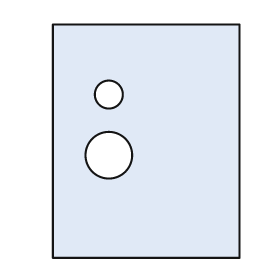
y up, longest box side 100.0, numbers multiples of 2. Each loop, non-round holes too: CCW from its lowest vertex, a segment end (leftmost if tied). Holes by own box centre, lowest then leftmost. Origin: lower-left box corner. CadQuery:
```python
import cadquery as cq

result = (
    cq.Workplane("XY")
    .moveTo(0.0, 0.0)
    .lineTo(80.0, 0.0)
    .lineTo(80.0, 100.0)
    .lineTo(0.0, 100.0)
    .close()
    .moveTo(24.0, 44.0)
    .circle(10.0)
    .moveTo(24.0, 70.0)
    .circle(6.0)
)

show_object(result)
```